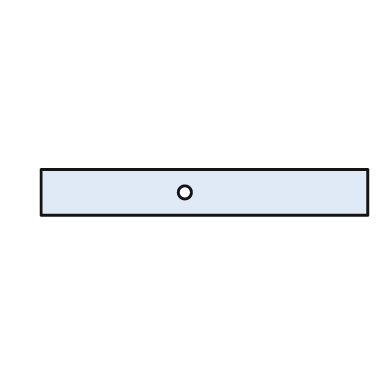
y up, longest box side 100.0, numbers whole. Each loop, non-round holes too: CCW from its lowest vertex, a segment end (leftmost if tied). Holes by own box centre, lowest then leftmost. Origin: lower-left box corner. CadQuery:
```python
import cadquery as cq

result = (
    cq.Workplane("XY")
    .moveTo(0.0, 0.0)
    .lineTo(100.0, 0.0)
    .lineTo(100.0, 14.0)
    .lineTo(0.0, 14.0)
    .close()
    .moveTo(44.0, 7.0)
    .circle(2.0)
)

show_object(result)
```